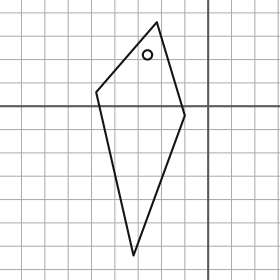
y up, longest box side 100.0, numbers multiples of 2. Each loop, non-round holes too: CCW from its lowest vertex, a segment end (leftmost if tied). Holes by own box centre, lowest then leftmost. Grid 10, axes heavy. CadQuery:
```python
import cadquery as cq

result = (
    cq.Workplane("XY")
    .moveTo(-32.0, -64.0)
    .lineTo(-10.0, -4.0)
    .lineTo(-22.0, 36.0)
    .lineTo(-48.0, 6.0)
    .close()
    .moveTo(-26.0, 22.0)
    .circle(2.0)
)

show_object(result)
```